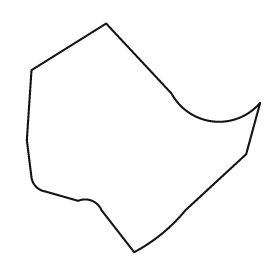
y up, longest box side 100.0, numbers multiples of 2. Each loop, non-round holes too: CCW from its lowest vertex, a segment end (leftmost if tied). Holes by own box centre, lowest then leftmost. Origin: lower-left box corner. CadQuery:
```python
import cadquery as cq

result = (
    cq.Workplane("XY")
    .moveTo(46.0, 0.0)
    .threePointArc((58.0, 8.0), (68.0, 18.0))
    .lineTo(94.0, 42.0)
    .lineTo(100.0, 64.0)
    .threePointArc((80.0, 56.0), (62.0, 68.0))
    .lineTo(34.0, 98.0)
    .lineTo(2.0, 78.0)
    .lineTo(0.0, 48.0)
    .lineTo(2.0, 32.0)
    .threePointArc((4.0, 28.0), (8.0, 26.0))
    .lineTo(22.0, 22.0)
    .threePointArc((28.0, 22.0), (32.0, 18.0))
    .close()
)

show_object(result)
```